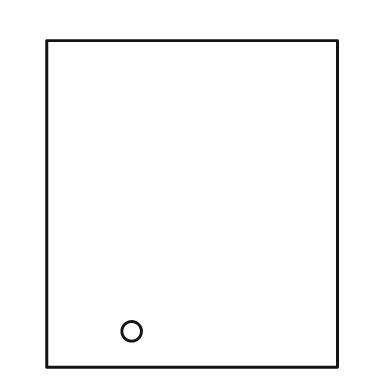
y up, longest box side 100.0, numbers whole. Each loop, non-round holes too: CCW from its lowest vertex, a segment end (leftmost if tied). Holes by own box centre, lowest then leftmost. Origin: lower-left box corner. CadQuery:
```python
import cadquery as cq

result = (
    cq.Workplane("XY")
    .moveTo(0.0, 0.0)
    .lineTo(89.0, 0.0)
    .lineTo(89.0, 100.0)
    .lineTo(0.0, 100.0)
    .close()
    .moveTo(26.0, 11.0)
    .circle(3.0)
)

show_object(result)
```